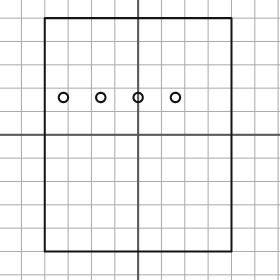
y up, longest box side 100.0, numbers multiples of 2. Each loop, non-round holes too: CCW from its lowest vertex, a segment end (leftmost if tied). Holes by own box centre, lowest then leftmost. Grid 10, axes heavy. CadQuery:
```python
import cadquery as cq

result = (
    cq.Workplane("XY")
    .moveTo(-40.0, -50.0)
    .lineTo(40.0, -50.0)
    .lineTo(40.0, 50.0)
    .lineTo(-40.0, 50.0)
    .close()
    .moveTo(-32.0, 16.0)
    .circle(2.0)
    .moveTo(-16.0, 16.0)
    .circle(2.0)
    .moveTo(0.0, 16.0)
    .circle(2.0)
    .moveTo(16.0, 16.0)
    .circle(2.0)
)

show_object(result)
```